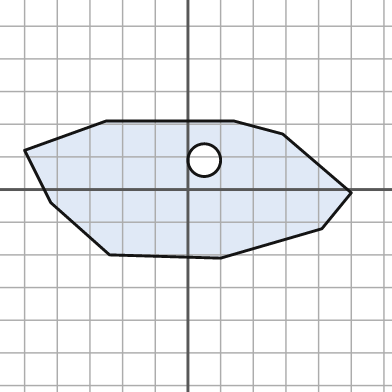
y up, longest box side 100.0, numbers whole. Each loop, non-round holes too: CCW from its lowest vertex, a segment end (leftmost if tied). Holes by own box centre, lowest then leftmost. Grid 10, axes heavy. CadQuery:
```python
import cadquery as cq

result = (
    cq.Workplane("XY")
    .moveTo(10.0, -21.0)
    .lineTo(41.0, -12.0)
    .lineTo(50.0, -1.0)
    .lineTo(29.0, 17.0)
    .lineTo(14.0, 21.0)
    .lineTo(-25.0, 21.0)
    .lineTo(-50.0, 12.0)
    .lineTo(-42.0, -4.0)
    .lineTo(-24.0, -20.0)
    .close()
    .moveTo(5.0, 9.0)
    .circle(5.0)
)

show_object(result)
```